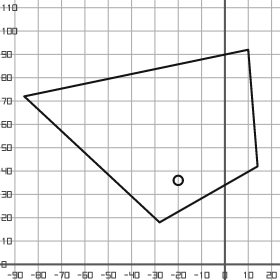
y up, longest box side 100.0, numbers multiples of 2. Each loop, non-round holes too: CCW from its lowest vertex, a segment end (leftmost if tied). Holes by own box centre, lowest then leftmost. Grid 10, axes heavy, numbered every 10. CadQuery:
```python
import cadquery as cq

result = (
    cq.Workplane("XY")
    .moveTo(-28.0, 18.0)
    .lineTo(14.0, 42.0)
    .lineTo(10.0, 92.0)
    .lineTo(-86.0, 72.0)
    .close()
    .moveTo(-20.0, 36.0)
    .circle(2.0)
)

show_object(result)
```